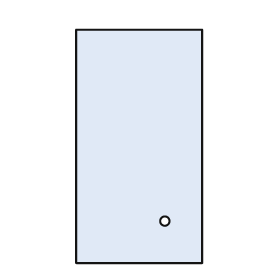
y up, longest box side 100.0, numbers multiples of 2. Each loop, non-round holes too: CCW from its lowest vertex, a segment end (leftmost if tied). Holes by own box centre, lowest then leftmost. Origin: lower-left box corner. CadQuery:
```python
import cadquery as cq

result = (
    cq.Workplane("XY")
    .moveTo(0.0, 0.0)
    .lineTo(54.0, 0.0)
    .lineTo(54.0, 100.0)
    .lineTo(0.0, 100.0)
    .close()
    .moveTo(38.0, 18.0)
    .circle(2.0)
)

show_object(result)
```